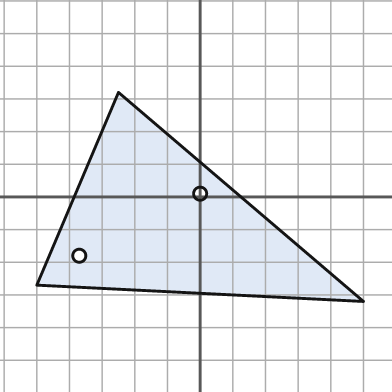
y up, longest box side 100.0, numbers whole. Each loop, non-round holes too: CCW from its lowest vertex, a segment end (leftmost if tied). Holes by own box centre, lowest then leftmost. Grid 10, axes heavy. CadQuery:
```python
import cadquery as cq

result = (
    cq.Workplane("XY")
    .moveTo(50.0, -32.0)
    .lineTo(-25.0, 32.0)
    .lineTo(-50.0, -27.0)
    .close()
    .moveTo(-37.0, -18.0)
    .circle(2.0)
    .moveTo(0.0, 1.0)
    .circle(2.0)
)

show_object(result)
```